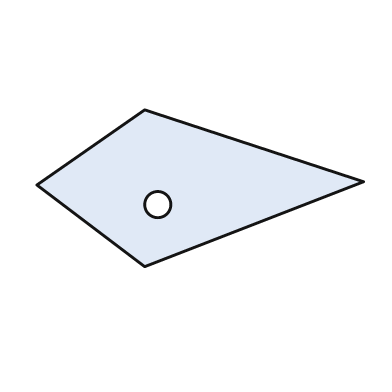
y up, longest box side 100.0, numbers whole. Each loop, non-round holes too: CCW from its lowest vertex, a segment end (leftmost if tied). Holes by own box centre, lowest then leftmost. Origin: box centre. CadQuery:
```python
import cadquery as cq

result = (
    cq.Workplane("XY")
    .moveTo(-17.0, -24.0)
    .lineTo(50.0, 2.0)
    .lineTo(-17.0, 24.0)
    .lineTo(-50.0, 1.0)
    .close()
    .moveTo(-13.0, -5.0)
    .circle(4.0)
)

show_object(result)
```